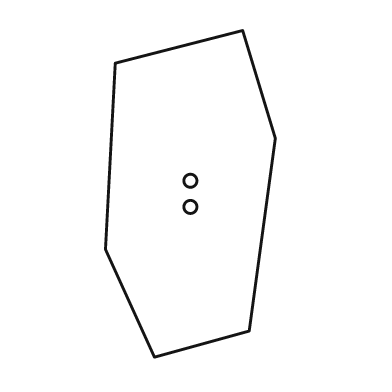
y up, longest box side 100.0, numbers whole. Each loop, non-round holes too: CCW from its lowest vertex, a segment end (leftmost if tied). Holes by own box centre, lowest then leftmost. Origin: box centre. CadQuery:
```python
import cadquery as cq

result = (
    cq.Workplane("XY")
    .moveTo(-11.0, -50.0)
    .lineTo(18.0, -42.0)
    .lineTo(26.0, 17.0)
    .lineTo(16.0, 50.0)
    .lineTo(-23.0, 40.0)
    .lineTo(-26.0, -17.0)
    .close()
    .moveTo(0.0, -4.0)
    .circle(2.0)
    .moveTo(0.0, 4.0)
    .circle(2.0)
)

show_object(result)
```